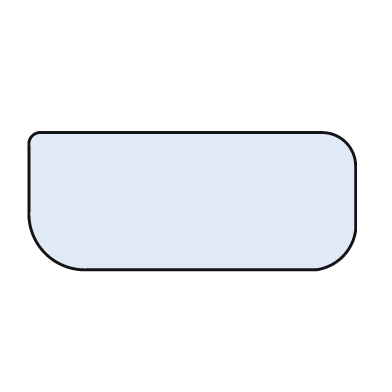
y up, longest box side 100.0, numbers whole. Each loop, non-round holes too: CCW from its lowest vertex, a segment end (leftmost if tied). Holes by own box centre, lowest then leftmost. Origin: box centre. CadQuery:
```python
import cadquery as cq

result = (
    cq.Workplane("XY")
    .moveTo(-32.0, -21.0)
    .lineTo(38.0, -21.0)
    .threePointArc((46.0, -17.0), (50.0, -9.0))
    .lineTo(50.0, 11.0)
    .threePointArc((47.0, 18.0), (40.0, 21.0))
    .lineTo(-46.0, 21.0)
    .threePointArc((-49.0, 20.0), (-50.0, 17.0))
    .lineTo(-50.0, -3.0)
    .threePointArc((-45.0, -16.0), (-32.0, -21.0))
    .close()
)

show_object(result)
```